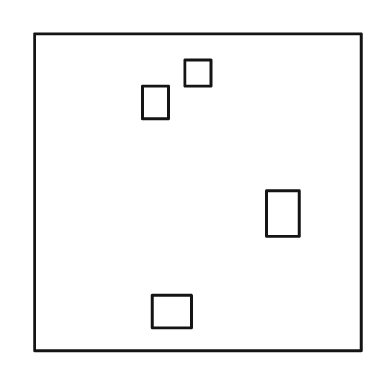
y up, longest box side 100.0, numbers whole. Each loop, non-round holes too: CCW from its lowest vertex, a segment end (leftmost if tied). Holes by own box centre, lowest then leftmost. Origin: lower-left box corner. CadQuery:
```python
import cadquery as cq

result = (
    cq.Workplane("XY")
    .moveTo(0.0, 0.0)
    .lineTo(100.0, 0.0)
    .lineTo(100.0, 97.0)
    .lineTo(0.0, 97.0)
    .close()
    .moveTo(36.0, 7.0)
    .lineTo(48.0, 7.0)
    .lineTo(48.0, 17.0)
    .lineTo(36.0, 17.0)
    .close()
    .moveTo(71.0, 35.0)
    .lineTo(81.0, 35.0)
    .lineTo(81.0, 49.0)
    .lineTo(71.0, 49.0)
    .close()
    .moveTo(33.0, 71.0)
    .lineTo(41.0, 71.0)
    .lineTo(41.0, 81.0)
    .lineTo(33.0, 81.0)
    .close()
    .moveTo(46.0, 81.0)
    .lineTo(54.0, 81.0)
    .lineTo(54.0, 89.0)
    .lineTo(46.0, 89.0)
    .close()
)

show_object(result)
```